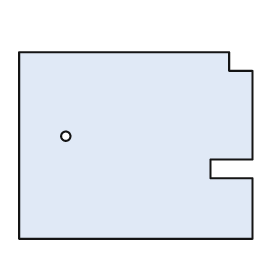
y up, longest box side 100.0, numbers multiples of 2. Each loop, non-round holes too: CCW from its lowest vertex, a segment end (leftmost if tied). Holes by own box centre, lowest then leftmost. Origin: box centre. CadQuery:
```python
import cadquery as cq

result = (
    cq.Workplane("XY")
    .moveTo(-50.0, -40.0)
    .lineTo(50.0, -40.0)
    .lineTo(50.0, -14.0)
    .lineTo(32.0, -14.0)
    .lineTo(32.0, -6.0)
    .lineTo(50.0, -6.0)
    .lineTo(50.0, 32.0)
    .lineTo(40.0, 32.0)
    .lineTo(40.0, 40.0)
    .lineTo(-50.0, 40.0)
    .close()
    .moveTo(-30.0, 4.0)
    .circle(2.0)
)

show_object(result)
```